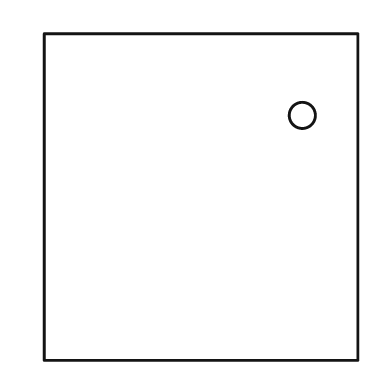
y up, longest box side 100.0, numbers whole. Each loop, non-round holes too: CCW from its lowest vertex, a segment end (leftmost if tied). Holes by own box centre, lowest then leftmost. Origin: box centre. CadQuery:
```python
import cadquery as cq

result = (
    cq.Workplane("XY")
    .moveTo(-48.0, -50.0)
    .lineTo(48.0, -50.0)
    .lineTo(48.0, 50.0)
    .lineTo(-48.0, 50.0)
    .close()
    .moveTo(31.0, 25.0)
    .circle(4.0)
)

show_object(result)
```